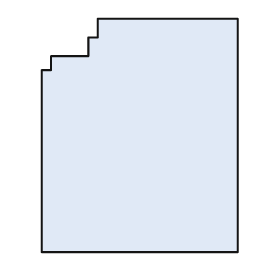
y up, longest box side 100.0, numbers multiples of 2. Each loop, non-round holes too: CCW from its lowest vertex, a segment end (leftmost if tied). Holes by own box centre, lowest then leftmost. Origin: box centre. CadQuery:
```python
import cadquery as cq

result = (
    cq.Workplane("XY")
    .moveTo(-42.0, -50.0)
    .lineTo(42.0, -50.0)
    .lineTo(42.0, 50.0)
    .lineTo(-18.0, 50.0)
    .lineTo(-18.0, 42.0)
    .lineTo(-22.0, 42.0)
    .lineTo(-22.0, 34.0)
    .lineTo(-38.0, 34.0)
    .lineTo(-38.0, 28.0)
    .lineTo(-42.0, 28.0)
    .close()
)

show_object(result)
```